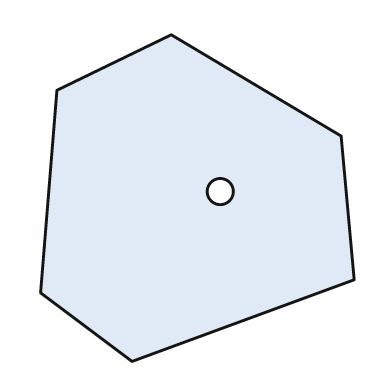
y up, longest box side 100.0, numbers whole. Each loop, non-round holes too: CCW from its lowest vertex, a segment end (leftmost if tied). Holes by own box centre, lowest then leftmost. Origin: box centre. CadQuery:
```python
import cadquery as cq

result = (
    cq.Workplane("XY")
    .moveTo(-20.0, -50.0)
    .lineTo(48.0, -25.0)
    .lineTo(44.0, 19.0)
    .lineTo(-8.0, 50.0)
    .lineTo(-43.0, 33.0)
    .lineTo(-48.0, -29.0)
    .close()
    .moveTo(7.0, 2.0)
    .circle(4.0)
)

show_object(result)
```